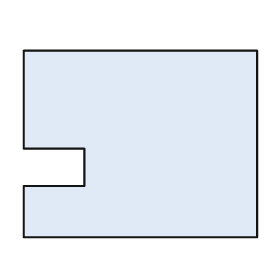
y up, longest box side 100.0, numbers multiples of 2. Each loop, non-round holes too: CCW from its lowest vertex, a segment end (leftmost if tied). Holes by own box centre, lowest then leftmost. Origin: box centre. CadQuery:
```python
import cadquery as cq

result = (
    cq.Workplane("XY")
    .moveTo(-50.0, -40.0)
    .lineTo(50.0, -40.0)
    .lineTo(50.0, 40.0)
    .lineTo(-50.0, 40.0)
    .lineTo(-50.0, -2.0)
    .lineTo(-24.0, -2.0)
    .lineTo(-24.0, -18.0)
    .lineTo(-50.0, -18.0)
    .close()
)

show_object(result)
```